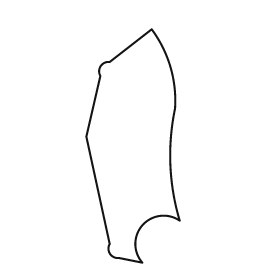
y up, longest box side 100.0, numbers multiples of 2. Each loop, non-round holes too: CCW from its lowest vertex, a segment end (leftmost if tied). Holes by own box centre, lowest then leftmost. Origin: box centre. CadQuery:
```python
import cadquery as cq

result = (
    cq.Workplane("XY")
    .moveTo(4.0, -50.0)
    .threePointArc((4.0, -34.0), (20.0, -32.0))
    .threePointArc((16.0, -8.0), (18.0, 16.0))
    .threePointArc((16.0, 34.0), (8.0, 50.0))
    .lineTo(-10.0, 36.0)
    .threePointArc((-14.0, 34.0), (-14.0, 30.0))
    .lineTo(-20.0, 4.0)
    .lineTo(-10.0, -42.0)
    .threePointArc((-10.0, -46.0), (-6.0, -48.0))
    .close()
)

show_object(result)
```